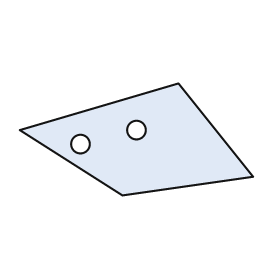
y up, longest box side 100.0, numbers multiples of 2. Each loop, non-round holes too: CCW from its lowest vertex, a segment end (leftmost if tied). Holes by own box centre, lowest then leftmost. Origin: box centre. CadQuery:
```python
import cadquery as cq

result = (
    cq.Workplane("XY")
    .moveTo(-6.0, -24.0)
    .lineTo(50.0, -16.0)
    .lineTo(18.0, 24.0)
    .lineTo(-50.0, 4.0)
    .close()
    .moveTo(-24.0, -2.0)
    .circle(4.0)
    .moveTo(0.0, 4.0)
    .circle(4.0)
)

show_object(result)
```